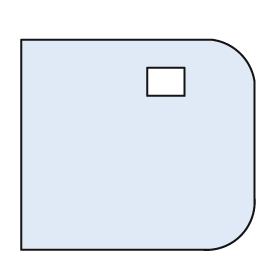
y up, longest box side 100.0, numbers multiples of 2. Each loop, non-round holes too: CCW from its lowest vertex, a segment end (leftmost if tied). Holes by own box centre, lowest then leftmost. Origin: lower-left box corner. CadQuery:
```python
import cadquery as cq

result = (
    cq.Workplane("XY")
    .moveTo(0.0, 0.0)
    .lineTo(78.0, 0.0)
    .threePointArc((94.0, 6.0), (100.0, 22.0))
    .lineTo(100.0, 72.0)
    .threePointArc((94.0, 84.0), (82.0, 90.0))
    .lineTo(0.0, 90.0)
    .close()
    .moveTo(54.0, 66.0)
    .lineTo(70.0, 66.0)
    .lineTo(70.0, 78.0)
    .lineTo(54.0, 78.0)
    .close()
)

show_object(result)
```